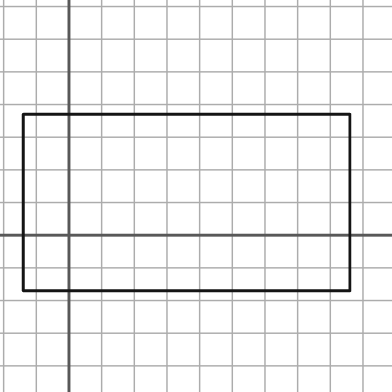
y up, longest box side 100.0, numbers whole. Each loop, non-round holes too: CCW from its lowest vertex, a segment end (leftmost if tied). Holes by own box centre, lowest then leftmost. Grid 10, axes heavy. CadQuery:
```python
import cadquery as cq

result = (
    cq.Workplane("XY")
    .moveTo(-14.0, -17.0)
    .lineTo(86.0, -17.0)
    .lineTo(86.0, 37.0)
    .lineTo(-14.0, 37.0)
    .close()
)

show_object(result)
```